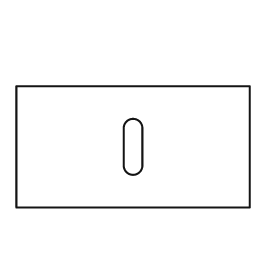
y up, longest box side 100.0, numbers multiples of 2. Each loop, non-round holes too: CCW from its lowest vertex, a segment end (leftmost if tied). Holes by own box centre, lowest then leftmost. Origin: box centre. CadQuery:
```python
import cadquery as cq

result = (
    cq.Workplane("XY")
    .moveTo(-50.0, -26.0)
    .lineTo(50.0, -26.0)
    .lineTo(50.0, 26.0)
    .lineTo(-50.0, 26.0)
    .close()
    .moveTo(-4.0, -8.0)
    .threePointArc((0.0, -12.0), (4.0, -8.0))
    .lineTo(4.0, 8.0)
    .threePointArc((0.0, 12.0), (-4.0, 8.0))
    .close()
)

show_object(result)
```